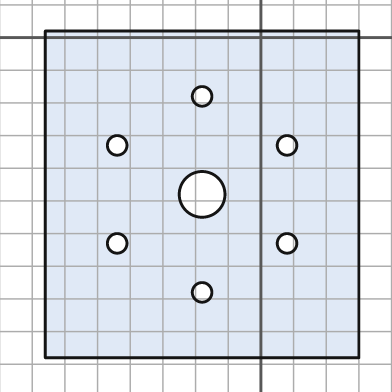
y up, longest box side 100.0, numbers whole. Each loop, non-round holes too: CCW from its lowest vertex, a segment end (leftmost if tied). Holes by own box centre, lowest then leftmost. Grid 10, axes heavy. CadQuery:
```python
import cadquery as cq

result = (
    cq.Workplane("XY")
    .moveTo(-66.0, -98.0)
    .lineTo(30.0, -98.0)
    .lineTo(30.0, 2.0)
    .lineTo(-66.0, 2.0)
    .close()
    .moveTo(-18.0, -78.0)
    .circle(3.0)
    .moveTo(-44.0, -63.0)
    .circle(3.0)
    .moveTo(8.0, -63.0)
    .circle(3.0)
    .moveTo(-18.0, -48.0)
    .circle(7.0)
    .moveTo(-44.0, -33.0)
    .circle(3.0)
    .moveTo(8.0, -33.0)
    .circle(3.0)
    .moveTo(-18.0, -18.0)
    .circle(3.0)
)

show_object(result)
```